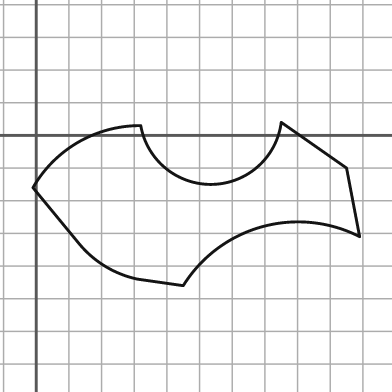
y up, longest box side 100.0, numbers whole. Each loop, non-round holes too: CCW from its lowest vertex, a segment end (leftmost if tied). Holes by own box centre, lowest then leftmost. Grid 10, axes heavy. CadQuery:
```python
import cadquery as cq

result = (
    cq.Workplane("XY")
    .moveTo(45.0, -46.0)
    .threePointArc((69.0, -28.0), (99.0, -31.0))
    .lineTo(95.0, -10.0)
    .lineTo(75.0, 4.0)
    .threePointArc((54.0, -15.0), (32.0, 3.0))
    .threePointArc((13.0, -2.0), (-1.0, -16.0))
    .lineTo(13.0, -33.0)
    .threePointArc((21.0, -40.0), (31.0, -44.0))
    .close()
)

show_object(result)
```